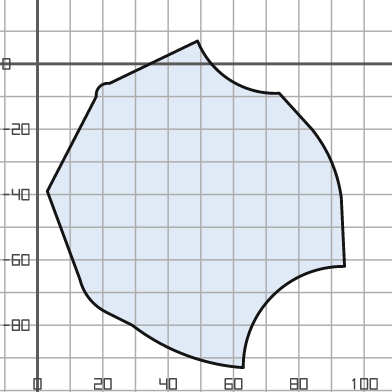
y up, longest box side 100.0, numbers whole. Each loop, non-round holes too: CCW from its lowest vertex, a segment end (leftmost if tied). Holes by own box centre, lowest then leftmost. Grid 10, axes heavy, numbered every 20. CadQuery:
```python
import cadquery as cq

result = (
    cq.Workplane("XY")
    .moveTo(63.0, -93.0)
    .threePointArc((72.0, -71.0), (94.0, -62.0))
    .lineTo(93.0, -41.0)
    .threePointArc((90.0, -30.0), (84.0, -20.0))
    .lineTo(74.0, -9.0)
    .threePointArc((59.0, -5.0), (49.0, 7.0))
    .lineTo(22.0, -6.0)
    .threePointArc((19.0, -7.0), (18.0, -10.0))
    .lineTo(3.0, -39.0)
    .lineTo(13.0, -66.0)
    .threePointArc((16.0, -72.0), (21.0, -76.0))
    .lineTo(29.0, -80.0)
    .threePointArc((45.0, -89.0), (63.0, -93.0))
    .close()
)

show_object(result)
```